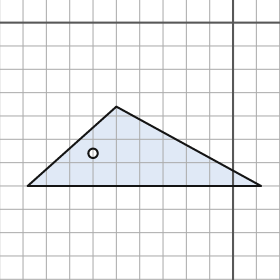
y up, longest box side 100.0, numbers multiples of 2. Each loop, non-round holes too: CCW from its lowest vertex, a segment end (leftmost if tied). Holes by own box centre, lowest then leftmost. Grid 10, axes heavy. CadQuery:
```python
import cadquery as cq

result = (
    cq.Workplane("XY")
    .moveTo(-88.0, -70.0)
    .lineTo(12.0, -70.0)
    .lineTo(-50.0, -36.0)
    .close()
    .moveTo(-60.0, -56.0)
    .circle(2.0)
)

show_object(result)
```